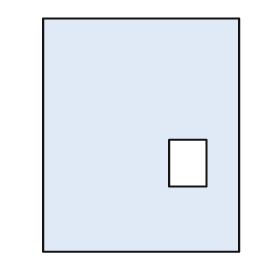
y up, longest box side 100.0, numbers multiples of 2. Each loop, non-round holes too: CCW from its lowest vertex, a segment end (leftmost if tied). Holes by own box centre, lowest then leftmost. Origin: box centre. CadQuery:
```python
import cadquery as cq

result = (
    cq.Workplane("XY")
    .moveTo(-42.0, -50.0)
    .lineTo(42.0, -50.0)
    .lineTo(42.0, 50.0)
    .lineTo(-42.0, 50.0)
    .close()
    .moveTo(12.0, -22.0)
    .lineTo(28.0, -22.0)
    .lineTo(28.0, -2.0)
    .lineTo(12.0, -2.0)
    .close()
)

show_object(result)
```